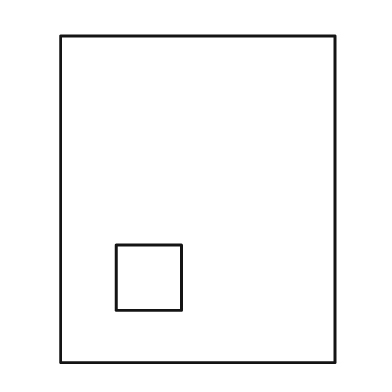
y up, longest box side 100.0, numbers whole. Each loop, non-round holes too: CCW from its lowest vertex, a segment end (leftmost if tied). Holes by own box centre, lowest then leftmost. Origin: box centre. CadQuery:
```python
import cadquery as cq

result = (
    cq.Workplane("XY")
    .moveTo(-42.0, -50.0)
    .lineTo(42.0, -50.0)
    .lineTo(42.0, 50.0)
    .lineTo(-42.0, 50.0)
    .close()
    .moveTo(-25.0, -34.0)
    .lineTo(-5.0, -34.0)
    .lineTo(-5.0, -14.0)
    .lineTo(-25.0, -14.0)
    .close()
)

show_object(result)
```